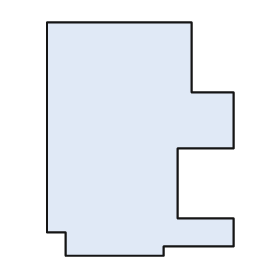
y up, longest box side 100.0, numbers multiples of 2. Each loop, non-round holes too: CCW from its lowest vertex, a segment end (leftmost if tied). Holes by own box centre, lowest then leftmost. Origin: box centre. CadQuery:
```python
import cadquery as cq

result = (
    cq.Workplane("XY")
    .moveTo(-32.0, -50.0)
    .lineTo(10.0, -50.0)
    .lineTo(10.0, -46.0)
    .lineTo(40.0, -46.0)
    .lineTo(40.0, -34.0)
    .lineTo(16.0, -34.0)
    .lineTo(16.0, -4.0)
    .lineTo(40.0, -4.0)
    .lineTo(40.0, 20.0)
    .lineTo(22.0, 20.0)
    .lineTo(22.0, 50.0)
    .lineTo(-40.0, 50.0)
    .lineTo(-40.0, -40.0)
    .lineTo(-32.0, -40.0)
    .close()
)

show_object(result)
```